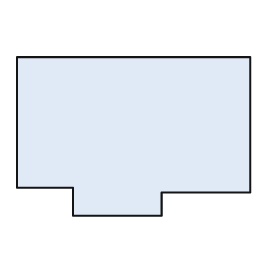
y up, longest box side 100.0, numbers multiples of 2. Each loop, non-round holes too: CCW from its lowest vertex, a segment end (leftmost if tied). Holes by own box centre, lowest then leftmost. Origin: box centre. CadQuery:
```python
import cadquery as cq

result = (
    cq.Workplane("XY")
    .moveTo(-26.0, -34.0)
    .lineTo(12.0, -34.0)
    .lineTo(12.0, -24.0)
    .lineTo(50.0, -24.0)
    .lineTo(50.0, 34.0)
    .lineTo(-50.0, 34.0)
    .lineTo(-50.0, -22.0)
    .lineTo(-26.0, -22.0)
    .close()
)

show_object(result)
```